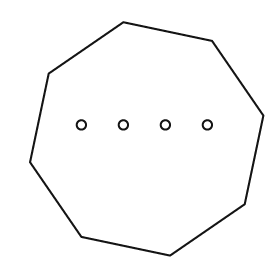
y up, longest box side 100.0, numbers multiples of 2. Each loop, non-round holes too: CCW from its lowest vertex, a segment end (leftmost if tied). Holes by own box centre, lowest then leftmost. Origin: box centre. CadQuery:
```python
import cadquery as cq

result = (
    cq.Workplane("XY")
    .moveTo(10.0, -50.0)
    .lineTo(42.0, -28.0)
    .lineTo(50.0, 10.0)
    .lineTo(28.0, 42.0)
    .lineTo(-10.0, 50.0)
    .lineTo(-42.0, 28.0)
    .lineTo(-50.0, -10.0)
    .lineTo(-28.0, -42.0)
    .close()
    .moveTo(-28.0, 6.0)
    .circle(2.0)
    .moveTo(-10.0, 6.0)
    .circle(2.0)
    .moveTo(8.0, 6.0)
    .circle(2.0)
    .moveTo(26.0, 6.0)
    .circle(2.0)
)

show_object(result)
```